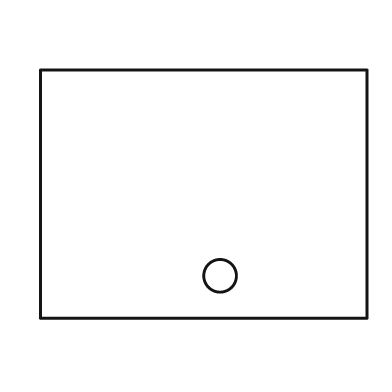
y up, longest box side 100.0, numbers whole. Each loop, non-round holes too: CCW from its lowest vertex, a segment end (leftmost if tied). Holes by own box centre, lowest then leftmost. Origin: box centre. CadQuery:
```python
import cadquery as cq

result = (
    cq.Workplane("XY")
    .moveTo(-50.0, -38.0)
    .lineTo(50.0, -38.0)
    .lineTo(50.0, 38.0)
    .lineTo(-50.0, 38.0)
    .close()
    .moveTo(5.0, -25.0)
    .circle(5.0)
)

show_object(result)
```